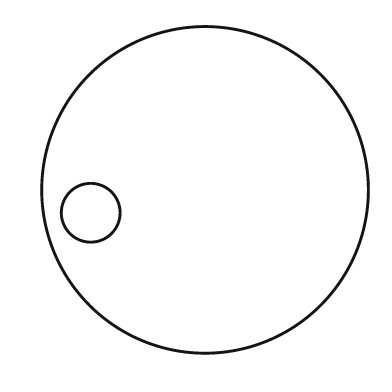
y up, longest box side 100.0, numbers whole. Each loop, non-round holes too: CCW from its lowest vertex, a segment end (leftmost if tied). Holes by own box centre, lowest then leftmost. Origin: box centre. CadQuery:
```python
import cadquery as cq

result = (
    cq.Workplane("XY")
    .moveTo(0.0, 0.0)
    .circle(50.0)
    .moveTo(-35.0, -7.0)
    .circle(9.0)
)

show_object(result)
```